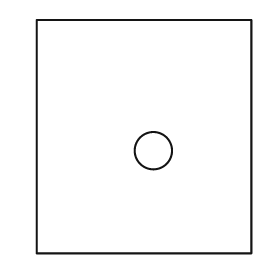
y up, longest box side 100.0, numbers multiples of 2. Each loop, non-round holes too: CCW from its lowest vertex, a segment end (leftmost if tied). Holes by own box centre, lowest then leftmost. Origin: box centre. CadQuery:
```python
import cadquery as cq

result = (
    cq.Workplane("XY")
    .moveTo(-46.0, -50.0)
    .lineTo(46.0, -50.0)
    .lineTo(46.0, 50.0)
    .lineTo(-46.0, 50.0)
    .close()
    .moveTo(4.0, -6.0)
    .circle(8.0)
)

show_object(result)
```